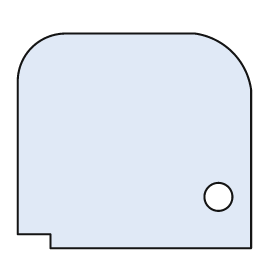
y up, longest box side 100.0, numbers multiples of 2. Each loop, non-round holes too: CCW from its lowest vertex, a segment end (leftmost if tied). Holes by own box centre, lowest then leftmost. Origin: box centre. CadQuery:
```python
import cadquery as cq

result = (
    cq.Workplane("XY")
    .moveTo(-36.0, -46.0)
    .lineTo(50.0, -46.0)
    .lineTo(50.0, 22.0)
    .threePointArc((42.0, 38.0), (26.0, 46.0))
    .lineTo(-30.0, 46.0)
    .threePointArc((-44.0, 40.0), (-50.0, 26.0))
    .lineTo(-50.0, -40.0)
    .lineTo(-36.0, -40.0)
    .close()
    .moveTo(36.0, -24.0)
    .circle(6.0)
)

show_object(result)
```